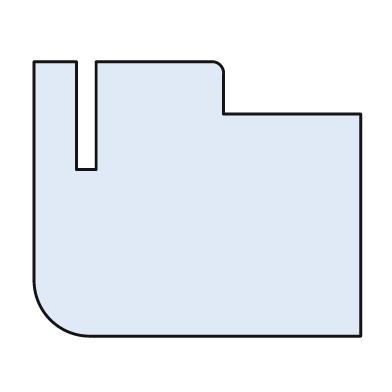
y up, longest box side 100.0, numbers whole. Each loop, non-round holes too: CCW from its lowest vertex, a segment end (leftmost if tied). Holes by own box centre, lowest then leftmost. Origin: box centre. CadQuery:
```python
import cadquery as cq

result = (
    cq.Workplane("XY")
    .moveTo(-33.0, -42.0)
    .lineTo(50.0, -42.0)
    .lineTo(50.0, 26.0)
    .lineTo(8.0, 26.0)
    .lineTo(8.0, 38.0)
    .threePointArc((7.0, 41.0), (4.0, 42.0))
    .lineTo(-31.0, 42.0)
    .lineTo(-31.0, 9.0)
    .lineTo(-37.0, 9.0)
    .lineTo(-37.0, 42.0)
    .lineTo(-50.0, 42.0)
    .lineTo(-50.0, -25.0)
    .threePointArc((-45.0, -37.0), (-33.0, -42.0))
    .close()
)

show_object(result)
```